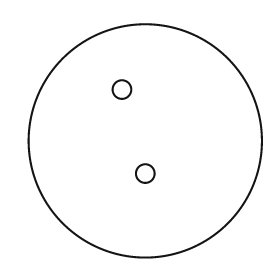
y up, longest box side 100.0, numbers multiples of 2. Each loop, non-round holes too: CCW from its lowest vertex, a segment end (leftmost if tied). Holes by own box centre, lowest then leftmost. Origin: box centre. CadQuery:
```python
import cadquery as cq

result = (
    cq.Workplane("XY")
    .moveTo(0.0, 0.0)
    .circle(50.0)
    .moveTo(0.0, -14.0)
    .circle(4.0)
    .moveTo(-10.0, 22.0)
    .circle(4.0)
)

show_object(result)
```